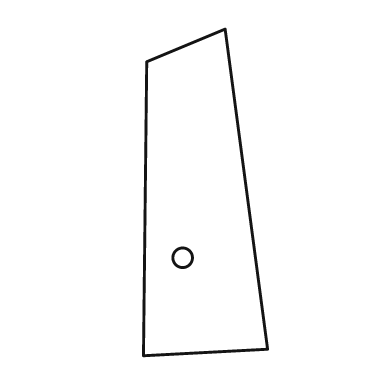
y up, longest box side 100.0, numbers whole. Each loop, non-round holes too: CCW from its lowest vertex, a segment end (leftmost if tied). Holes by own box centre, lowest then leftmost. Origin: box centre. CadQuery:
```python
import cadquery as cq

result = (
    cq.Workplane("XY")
    .moveTo(-19.0, -50.0)
    .lineTo(19.0, -48.0)
    .lineTo(6.0, 50.0)
    .lineTo(-18.0, 40.0)
    .close()
    .moveTo(-7.0, -20.0)
    .circle(3.0)
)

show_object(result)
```